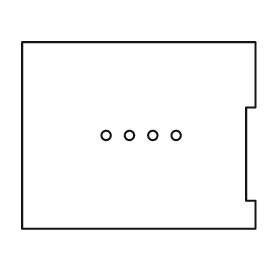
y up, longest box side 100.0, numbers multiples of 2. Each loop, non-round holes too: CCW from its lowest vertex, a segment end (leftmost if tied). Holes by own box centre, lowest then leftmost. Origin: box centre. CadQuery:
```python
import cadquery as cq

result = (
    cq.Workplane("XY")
    .moveTo(-50.0, -40.0)
    .lineTo(50.0, -40.0)
    .lineTo(50.0, -28.0)
    .lineTo(46.0, -28.0)
    .lineTo(46.0, 12.0)
    .lineTo(50.0, 12.0)
    .lineTo(50.0, 40.0)
    .lineTo(-50.0, 40.0)
    .close()
    .moveTo(-14.0, 0.0)
    .circle(2.0)
    .moveTo(-4.0, 0.0)
    .circle(2.0)
    .moveTo(6.0, 0.0)
    .circle(2.0)
    .moveTo(16.0, 0.0)
    .circle(2.0)
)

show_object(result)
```